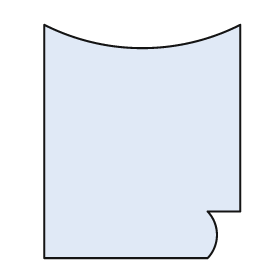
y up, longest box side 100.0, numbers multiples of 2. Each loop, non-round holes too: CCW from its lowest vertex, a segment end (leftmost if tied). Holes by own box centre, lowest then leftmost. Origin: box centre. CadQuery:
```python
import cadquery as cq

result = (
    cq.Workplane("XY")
    .moveTo(-42.0, -50.0)
    .lineTo(28.0, -50.0)
    .threePointArc((32.0, -40.0), (28.0, -30.0))
    .lineTo(42.0, -30.0)
    .lineTo(42.0, 50.0)
    .threePointArc((0.0, 40.0), (-42.0, 50.0))
    .close()
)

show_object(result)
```